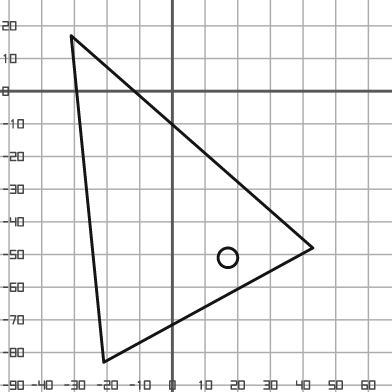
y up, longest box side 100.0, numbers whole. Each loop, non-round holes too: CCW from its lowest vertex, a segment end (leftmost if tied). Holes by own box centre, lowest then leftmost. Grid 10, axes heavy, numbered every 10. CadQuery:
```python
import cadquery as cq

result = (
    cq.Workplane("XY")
    .moveTo(-21.0, -83.0)
    .lineTo(43.0, -48.0)
    .lineTo(-31.0, 17.0)
    .close()
    .moveTo(17.0, -51.0)
    .circle(3.0)
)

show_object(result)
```